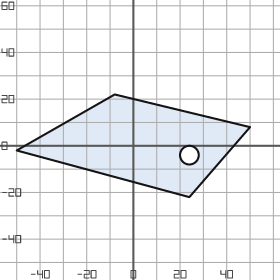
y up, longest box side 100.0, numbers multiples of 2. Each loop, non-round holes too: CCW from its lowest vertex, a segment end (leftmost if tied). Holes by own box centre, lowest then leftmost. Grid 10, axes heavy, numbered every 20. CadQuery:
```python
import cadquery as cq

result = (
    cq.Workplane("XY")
    .moveTo(24.0, -22.0)
    .lineTo(50.0, 8.0)
    .lineTo(-8.0, 22.0)
    .lineTo(-50.0, -2.0)
    .close()
    .moveTo(24.0, -4.0)
    .circle(4.0)
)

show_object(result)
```